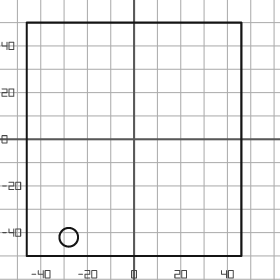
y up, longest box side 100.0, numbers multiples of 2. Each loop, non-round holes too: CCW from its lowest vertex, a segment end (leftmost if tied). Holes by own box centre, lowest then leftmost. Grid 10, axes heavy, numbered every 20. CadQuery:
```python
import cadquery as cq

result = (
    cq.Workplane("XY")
    .moveTo(-46.0, -50.0)
    .lineTo(46.0, -50.0)
    .lineTo(46.0, 50.0)
    .lineTo(-46.0, 50.0)
    .close()
    .moveTo(-28.0, -42.0)
    .circle(4.0)
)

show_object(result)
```